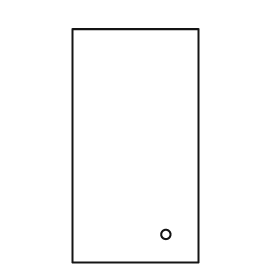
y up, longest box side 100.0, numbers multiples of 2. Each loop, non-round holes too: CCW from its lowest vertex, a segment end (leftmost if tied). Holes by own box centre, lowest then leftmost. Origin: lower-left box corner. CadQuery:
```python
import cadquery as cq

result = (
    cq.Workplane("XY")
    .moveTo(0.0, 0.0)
    .lineTo(54.0, 0.0)
    .lineTo(54.0, 100.0)
    .lineTo(0.0, 100.0)
    .close()
    .moveTo(40.0, 12.0)
    .circle(2.0)
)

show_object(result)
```